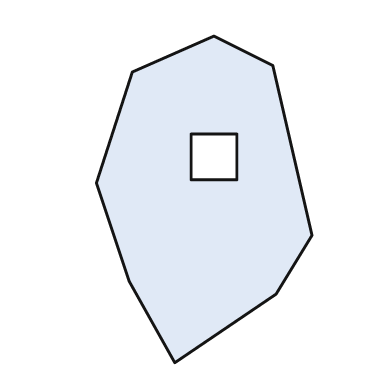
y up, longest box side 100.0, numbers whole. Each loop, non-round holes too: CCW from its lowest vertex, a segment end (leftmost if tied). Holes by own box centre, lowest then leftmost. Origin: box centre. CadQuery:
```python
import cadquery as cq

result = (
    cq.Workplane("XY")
    .moveTo(-9.0, -50.0)
    .lineTo(22.0, -29.0)
    .lineTo(33.0, -11.0)
    .lineTo(21.0, 41.0)
    .lineTo(3.0, 50.0)
    .lineTo(-22.0, 39.0)
    .lineTo(-33.0, 5.0)
    .lineTo(-23.0, -25.0)
    .close()
    .moveTo(-4.0, 6.0)
    .lineTo(10.0, 6.0)
    .lineTo(10.0, 20.0)
    .lineTo(-4.0, 20.0)
    .close()
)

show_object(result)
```